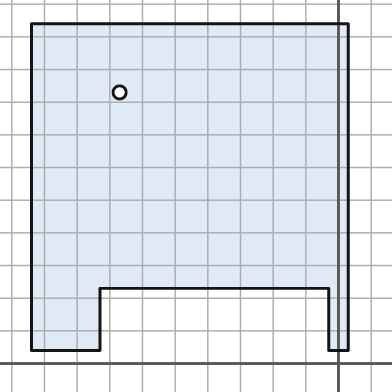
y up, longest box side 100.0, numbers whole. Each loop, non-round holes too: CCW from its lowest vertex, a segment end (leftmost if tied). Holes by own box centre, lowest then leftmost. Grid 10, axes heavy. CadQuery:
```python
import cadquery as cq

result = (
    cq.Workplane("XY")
    .moveTo(-94.0, 4.0)
    .lineTo(-73.0, 4.0)
    .lineTo(-73.0, 23.0)
    .lineTo(-3.0, 23.0)
    .lineTo(-3.0, 4.0)
    .lineTo(3.0, 4.0)
    .lineTo(3.0, 104.0)
    .lineTo(-94.0, 104.0)
    .close()
    .moveTo(-67.0, 83.0)
    .circle(2.0)
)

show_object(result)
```